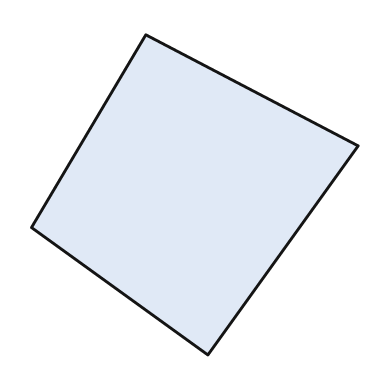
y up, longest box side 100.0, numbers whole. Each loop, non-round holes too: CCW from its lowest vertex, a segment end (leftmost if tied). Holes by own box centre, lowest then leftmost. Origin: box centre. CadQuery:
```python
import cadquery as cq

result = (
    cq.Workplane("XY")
    .moveTo(4.0, -49.0)
    .lineTo(50.0, 15.0)
    .lineTo(-15.0, 49.0)
    .lineTo(-50.0, -10.0)
    .close()
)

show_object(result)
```